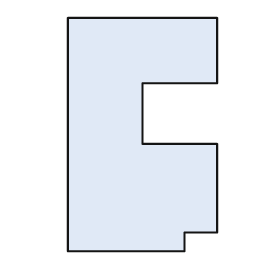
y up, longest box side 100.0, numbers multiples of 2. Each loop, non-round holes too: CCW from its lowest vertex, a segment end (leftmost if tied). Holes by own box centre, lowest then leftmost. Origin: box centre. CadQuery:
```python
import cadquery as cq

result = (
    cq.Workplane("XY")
    .moveTo(-32.0, -50.0)
    .lineTo(18.0, -50.0)
    .lineTo(18.0, -42.0)
    .lineTo(32.0, -42.0)
    .lineTo(32.0, -4.0)
    .lineTo(0.0, -4.0)
    .lineTo(0.0, 22.0)
    .lineTo(32.0, 22.0)
    .lineTo(32.0, 50.0)
    .lineTo(-32.0, 50.0)
    .close()
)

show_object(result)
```